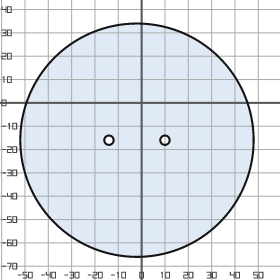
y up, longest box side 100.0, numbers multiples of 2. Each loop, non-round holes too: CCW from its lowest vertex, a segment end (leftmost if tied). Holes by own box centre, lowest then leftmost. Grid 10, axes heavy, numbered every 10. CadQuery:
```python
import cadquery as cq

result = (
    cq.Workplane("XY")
    .moveTo(-2.0, -16.0)
    .circle(50.0)
    .moveTo(-14.0, -16.0)
    .circle(2.0)
    .moveTo(10.0, -16.0)
    .circle(2.0)
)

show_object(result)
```